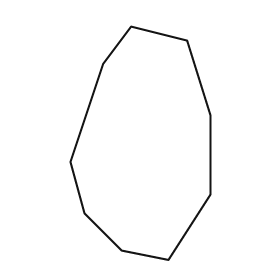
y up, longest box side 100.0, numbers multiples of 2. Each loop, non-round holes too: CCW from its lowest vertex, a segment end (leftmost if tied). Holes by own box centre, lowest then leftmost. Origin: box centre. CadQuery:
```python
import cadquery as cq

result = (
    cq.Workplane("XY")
    .moveTo(12.0, -50.0)
    .lineTo(30.0, -22.0)
    .lineTo(30.0, 12.0)
    .lineTo(20.0, 44.0)
    .lineTo(-4.0, 50.0)
    .lineTo(-16.0, 34.0)
    .lineTo(-30.0, -8.0)
    .lineTo(-24.0, -30.0)
    .lineTo(-8.0, -46.0)
    .close()
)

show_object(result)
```